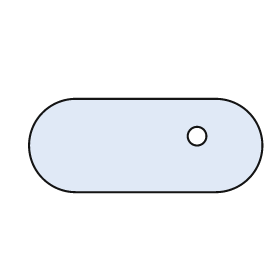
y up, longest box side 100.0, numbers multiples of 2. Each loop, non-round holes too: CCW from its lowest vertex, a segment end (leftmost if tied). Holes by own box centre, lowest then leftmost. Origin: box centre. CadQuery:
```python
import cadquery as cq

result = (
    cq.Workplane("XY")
    .moveTo(-30.0, -20.0)
    .lineTo(30.0, -20.0)
    .threePointArc((50.0, 0.0), (30.0, 20.0))
    .lineTo(-30.0, 20.0)
    .threePointArc((-50.0, 0.0), (-30.0, -20.0))
    .close()
    .moveTo(22.0, 4.0)
    .circle(4.0)
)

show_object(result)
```